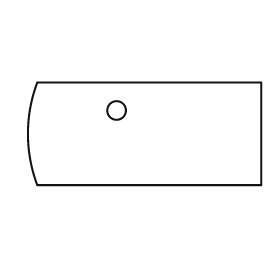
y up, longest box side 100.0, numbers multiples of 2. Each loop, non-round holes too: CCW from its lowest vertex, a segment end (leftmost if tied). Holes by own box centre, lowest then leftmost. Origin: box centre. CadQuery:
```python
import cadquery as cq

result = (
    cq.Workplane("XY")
    .moveTo(-46.0, -22.0)
    .lineTo(50.0, -22.0)
    .lineTo(50.0, 22.0)
    .lineTo(-46.0, 22.0)
    .threePointArc((-50.0, 0.0), (-46.0, -22.0))
    .close()
    .moveTo(-12.0, 10.0)
    .circle(4.0)
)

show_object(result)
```